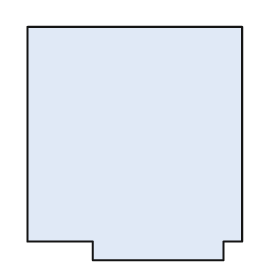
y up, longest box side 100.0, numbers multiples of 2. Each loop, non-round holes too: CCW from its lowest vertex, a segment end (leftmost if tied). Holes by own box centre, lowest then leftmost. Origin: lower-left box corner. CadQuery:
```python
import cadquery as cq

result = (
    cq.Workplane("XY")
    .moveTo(28.0, 0.0)
    .lineTo(84.0, 0.0)
    .lineTo(84.0, 8.0)
    .lineTo(92.0, 8.0)
    .lineTo(92.0, 100.0)
    .lineTo(0.0, 100.0)
    .lineTo(0.0, 8.0)
    .lineTo(28.0, 8.0)
    .close()
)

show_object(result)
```